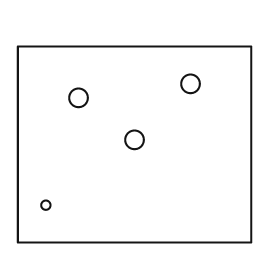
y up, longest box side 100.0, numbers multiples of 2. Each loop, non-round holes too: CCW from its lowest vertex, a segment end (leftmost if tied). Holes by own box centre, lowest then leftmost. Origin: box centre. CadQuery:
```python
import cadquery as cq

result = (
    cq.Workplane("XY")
    .moveTo(-50.0, -42.0)
    .lineTo(50.0, -42.0)
    .lineTo(50.0, 42.0)
    .lineTo(-50.0, 42.0)
    .close()
    .moveTo(-38.0, -26.0)
    .circle(2.0)
    .moveTo(0.0, 2.0)
    .circle(4.0)
    .moveTo(-24.0, 20.0)
    .circle(4.0)
    .moveTo(24.0, 26.0)
    .circle(4.0)
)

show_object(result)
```